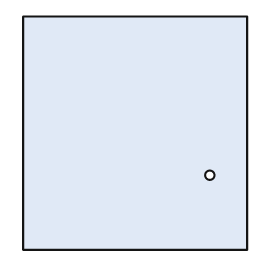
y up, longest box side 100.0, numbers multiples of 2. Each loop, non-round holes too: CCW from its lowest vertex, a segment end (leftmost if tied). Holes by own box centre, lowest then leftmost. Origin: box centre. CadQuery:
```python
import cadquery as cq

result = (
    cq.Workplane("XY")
    .moveTo(-48.0, -50.0)
    .lineTo(48.0, -50.0)
    .lineTo(48.0, 50.0)
    .lineTo(-48.0, 50.0)
    .close()
    .moveTo(32.0, -18.0)
    .circle(2.0)
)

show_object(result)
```